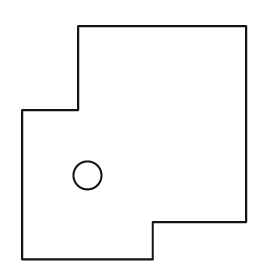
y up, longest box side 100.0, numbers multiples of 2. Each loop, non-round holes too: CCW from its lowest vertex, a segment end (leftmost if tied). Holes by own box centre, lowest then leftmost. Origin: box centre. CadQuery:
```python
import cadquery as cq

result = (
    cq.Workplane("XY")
    .moveTo(-48.0, -50.0)
    .lineTo(8.0, -50.0)
    .lineTo(8.0, -34.0)
    .lineTo(48.0, -34.0)
    .lineTo(48.0, 50.0)
    .lineTo(-24.0, 50.0)
    .lineTo(-24.0, 14.0)
    .lineTo(-48.0, 14.0)
    .close()
    .moveTo(-20.0, -14.0)
    .circle(6.0)
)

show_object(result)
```